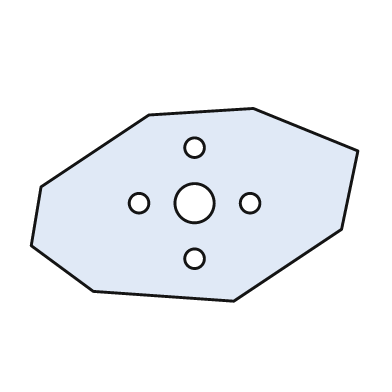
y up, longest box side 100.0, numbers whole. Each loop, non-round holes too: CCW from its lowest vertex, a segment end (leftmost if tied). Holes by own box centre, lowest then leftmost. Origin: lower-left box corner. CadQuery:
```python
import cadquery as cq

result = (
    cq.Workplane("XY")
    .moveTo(62.0, 0.0)
    .lineTo(95.0, 22.0)
    .lineTo(100.0, 46.0)
    .lineTo(68.0, 59.0)
    .lineTo(36.0, 57.0)
    .lineTo(3.0, 35.0)
    .lineTo(0.0, 17.0)
    .lineTo(19.0, 3.0)
    .close()
    .moveTo(50.0, 13.0)
    .circle(3.0)
    .moveTo(33.0, 30.0)
    .circle(3.0)
    .moveTo(50.0, 30.0)
    .circle(6.0)
    .moveTo(67.0, 30.0)
    .circle(3.0)
    .moveTo(50.0, 47.0)
    .circle(3.0)
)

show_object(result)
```